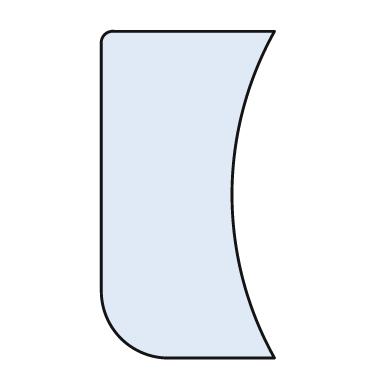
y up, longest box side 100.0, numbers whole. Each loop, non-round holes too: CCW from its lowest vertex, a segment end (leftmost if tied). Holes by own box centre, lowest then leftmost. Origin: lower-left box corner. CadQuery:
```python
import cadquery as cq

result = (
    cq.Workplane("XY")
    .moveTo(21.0, 0.0)
    .lineTo(53.0, 0.0)
    .threePointArc((40.0, 50.0), (53.0, 100.0))
    .lineTo(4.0, 100.0)
    .threePointArc((1.0, 99.0), (0.0, 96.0))
    .lineTo(0.0, 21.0)
    .threePointArc((6.0, 6.0), (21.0, 0.0))
    .close()
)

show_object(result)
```